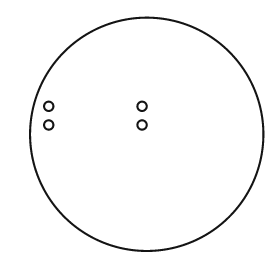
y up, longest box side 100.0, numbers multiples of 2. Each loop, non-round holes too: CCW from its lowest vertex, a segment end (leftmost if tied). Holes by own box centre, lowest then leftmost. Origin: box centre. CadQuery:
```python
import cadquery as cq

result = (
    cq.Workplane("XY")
    .moveTo(0.0, 0.0)
    .circle(50.0)
    .moveTo(-42.0, 4.0)
    .circle(2.0)
    .moveTo(-2.0, 4.0)
    .circle(2.0)
    .moveTo(-42.0, 12.0)
    .circle(2.0)
    .moveTo(-2.0, 12.0)
    .circle(2.0)
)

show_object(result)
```